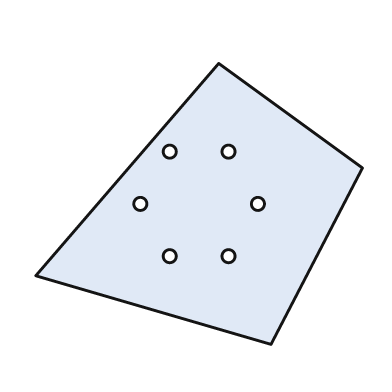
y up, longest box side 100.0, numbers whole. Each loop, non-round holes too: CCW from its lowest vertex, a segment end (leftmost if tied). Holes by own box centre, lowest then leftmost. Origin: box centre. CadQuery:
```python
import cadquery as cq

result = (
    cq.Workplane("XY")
    .moveTo(22.0, -43.0)
    .lineTo(50.0, 11.0)
    .lineTo(6.0, 43.0)
    .lineTo(-50.0, -22.0)
    .close()
    .moveTo(-9.0, -16.0)
    .circle(2.0)
    .moveTo(9.0, -16.0)
    .circle(2.0)
    .moveTo(-18.0, 0.0)
    .circle(2.0)
    .moveTo(18.0, 0.0)
    .circle(2.0)
    .moveTo(-9.0, 16.0)
    .circle(2.0)
    .moveTo(9.0, 16.0)
    .circle(2.0)
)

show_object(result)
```